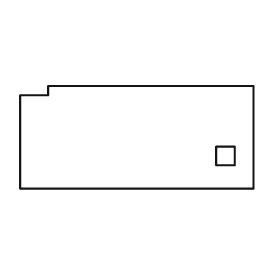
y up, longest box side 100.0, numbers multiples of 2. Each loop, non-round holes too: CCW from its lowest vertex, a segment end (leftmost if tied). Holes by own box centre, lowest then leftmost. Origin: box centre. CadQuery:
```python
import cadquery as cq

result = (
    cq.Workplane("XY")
    .moveTo(-50.0, -22.0)
    .lineTo(50.0, -22.0)
    .lineTo(50.0, 22.0)
    .lineTo(-38.0, 22.0)
    .lineTo(-38.0, 18.0)
    .lineTo(-50.0, 18.0)
    .close()
    .moveTo(34.0, -12.0)
    .lineTo(42.0, -12.0)
    .lineTo(42.0, -4.0)
    .lineTo(34.0, -4.0)
    .close()
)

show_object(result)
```